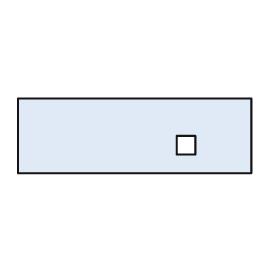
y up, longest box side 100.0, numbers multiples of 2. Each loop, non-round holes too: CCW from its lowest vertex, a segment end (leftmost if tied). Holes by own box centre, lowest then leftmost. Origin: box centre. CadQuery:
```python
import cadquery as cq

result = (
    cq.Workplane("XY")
    .moveTo(-50.0, -16.0)
    .lineTo(50.0, -16.0)
    .lineTo(50.0, 16.0)
    .lineTo(-50.0, 16.0)
    .close()
    .moveTo(18.0, -8.0)
    .lineTo(26.0, -8.0)
    .lineTo(26.0, 0.0)
    .lineTo(18.0, 0.0)
    .close()
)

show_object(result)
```